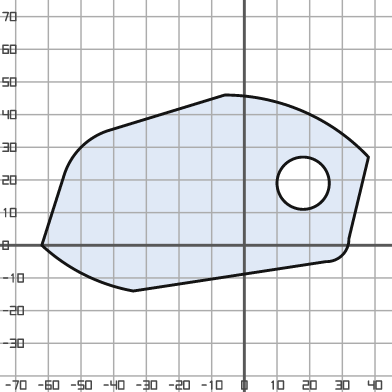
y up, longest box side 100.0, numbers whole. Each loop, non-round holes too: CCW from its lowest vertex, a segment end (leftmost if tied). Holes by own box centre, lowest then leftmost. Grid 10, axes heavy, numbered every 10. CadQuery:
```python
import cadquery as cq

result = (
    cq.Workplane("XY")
    .moveTo(-34.0, -14.0)
    .lineTo(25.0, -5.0)
    .threePointArc((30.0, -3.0), (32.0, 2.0))
    .lineTo(38.0, 27.0)
    .threePointArc((18.0, 41.0), (-6.0, 46.0))
    .lineTo(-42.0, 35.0)
    .threePointArc((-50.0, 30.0), (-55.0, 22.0))
    .lineTo(-62.0, 0.0)
    .threePointArc((-49.0, -9.0), (-34.0, -14.0))
    .close()
    .moveTo(18.0, 19.0)
    .circle(8.0)
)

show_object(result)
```